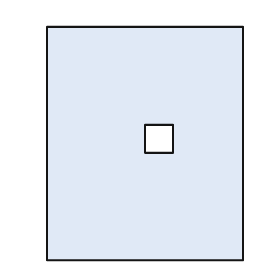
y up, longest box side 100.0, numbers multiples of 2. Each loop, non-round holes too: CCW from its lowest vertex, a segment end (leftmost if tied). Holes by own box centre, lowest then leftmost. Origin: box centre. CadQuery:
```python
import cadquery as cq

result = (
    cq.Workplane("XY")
    .moveTo(-42.0, -50.0)
    .lineTo(42.0, -50.0)
    .lineTo(42.0, 50.0)
    .lineTo(-42.0, 50.0)
    .close()
    .moveTo(0.0, -4.0)
    .lineTo(12.0, -4.0)
    .lineTo(12.0, 8.0)
    .lineTo(0.0, 8.0)
    .close()
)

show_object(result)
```